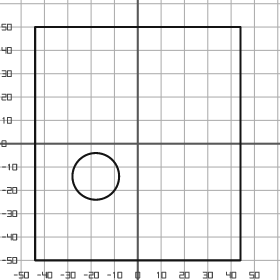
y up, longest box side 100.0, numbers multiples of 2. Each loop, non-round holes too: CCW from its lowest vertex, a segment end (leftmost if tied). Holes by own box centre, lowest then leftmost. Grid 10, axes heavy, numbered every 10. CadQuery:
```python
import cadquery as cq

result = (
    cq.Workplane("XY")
    .moveTo(-44.0, -50.0)
    .lineTo(44.0, -50.0)
    .lineTo(44.0, 50.0)
    .lineTo(-44.0, 50.0)
    .close()
    .moveTo(-18.0, -14.0)
    .circle(10.0)
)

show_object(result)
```